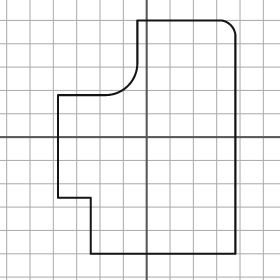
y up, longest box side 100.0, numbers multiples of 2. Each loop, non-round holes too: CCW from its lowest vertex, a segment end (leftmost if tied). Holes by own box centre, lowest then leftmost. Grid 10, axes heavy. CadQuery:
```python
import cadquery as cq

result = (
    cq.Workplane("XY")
    .moveTo(-24.0, -50.0)
    .lineTo(38.0, -50.0)
    .lineTo(38.0, 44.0)
    .threePointArc((36.0, 48.0), (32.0, 50.0))
    .lineTo(-4.0, 50.0)
    .lineTo(-4.0, 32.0)
    .threePointArc((-8.0, 22.0), (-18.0, 18.0))
    .lineTo(-38.0, 18.0)
    .lineTo(-38.0, -26.0)
    .lineTo(-24.0, -26.0)
    .close()
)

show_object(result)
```